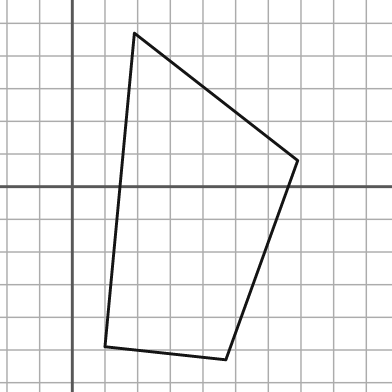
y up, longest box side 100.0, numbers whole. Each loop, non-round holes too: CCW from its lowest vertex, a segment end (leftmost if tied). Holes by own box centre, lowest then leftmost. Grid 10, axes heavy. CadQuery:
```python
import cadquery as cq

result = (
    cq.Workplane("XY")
    .moveTo(47.0, -53.0)
    .lineTo(69.0, 8.0)
    .lineTo(19.0, 47.0)
    .lineTo(10.0, -49.0)
    .close()
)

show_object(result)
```